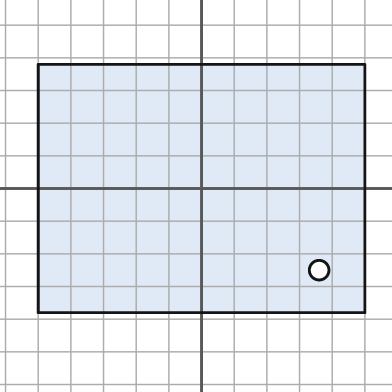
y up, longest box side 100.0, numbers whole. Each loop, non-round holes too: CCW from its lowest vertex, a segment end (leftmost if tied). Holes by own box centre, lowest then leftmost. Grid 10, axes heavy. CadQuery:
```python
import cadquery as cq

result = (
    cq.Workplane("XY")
    .moveTo(-50.0, -38.0)
    .lineTo(50.0, -38.0)
    .lineTo(50.0, 38.0)
    .lineTo(-50.0, 38.0)
    .close()
    .moveTo(36.0, -25.0)
    .circle(3.0)
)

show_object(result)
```